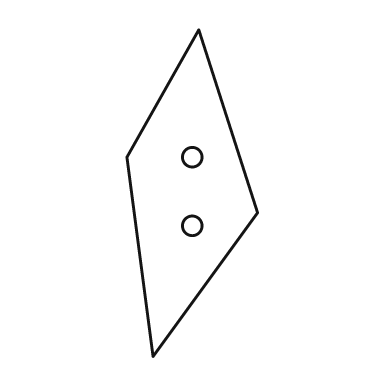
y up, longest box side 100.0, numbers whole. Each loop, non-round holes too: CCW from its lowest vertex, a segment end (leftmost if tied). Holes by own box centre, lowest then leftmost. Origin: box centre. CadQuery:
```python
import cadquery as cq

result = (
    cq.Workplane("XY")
    .moveTo(-12.0, -50.0)
    .lineTo(20.0, -6.0)
    .lineTo(2.0, 50.0)
    .lineTo(-20.0, 11.0)
    .close()
    .moveTo(0.0, -10.0)
    .circle(3.0)
    .moveTo(0.0, 11.0)
    .circle(3.0)
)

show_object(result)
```